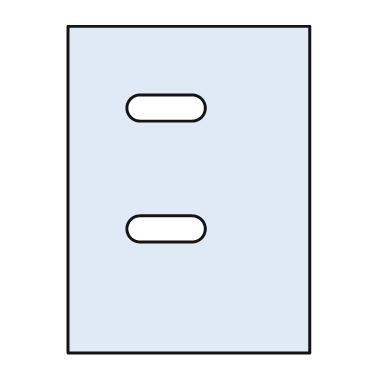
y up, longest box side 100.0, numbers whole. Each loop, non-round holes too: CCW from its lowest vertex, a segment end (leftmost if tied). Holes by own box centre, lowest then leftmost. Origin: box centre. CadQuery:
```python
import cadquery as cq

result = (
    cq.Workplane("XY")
    .moveTo(-37.0, -50.0)
    .lineTo(37.0, -50.0)
    .lineTo(37.0, 50.0)
    .lineTo(-37.0, 50.0)
    .close()
    .moveTo(-15.0, -16.0)
    .lineTo(1.0, -16.0)
    .threePointArc((5.0, -12.0), (1.0, -8.0))
    .lineTo(-15.0, -8.0)
    .threePointArc((-19.0, -12.0), (-15.0, -16.0))
    .close()
    .moveTo(-15.0, 21.0)
    .lineTo(1.0, 21.0)
    .threePointArc((5.0, 25.0), (1.0, 29.0))
    .lineTo(-15.0, 29.0)
    .threePointArc((-19.0, 25.0), (-15.0, 21.0))
    .close()
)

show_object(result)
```